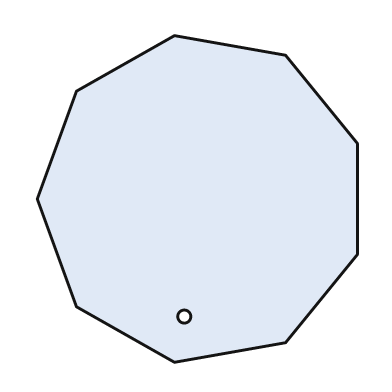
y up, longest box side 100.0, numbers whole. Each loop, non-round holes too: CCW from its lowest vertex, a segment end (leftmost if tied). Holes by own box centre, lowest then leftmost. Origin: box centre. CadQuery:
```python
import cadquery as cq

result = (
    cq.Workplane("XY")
    .moveTo(-7.0, -50.0)
    .lineTo(27.0, -44.0)
    .lineTo(49.0, -17.0)
    .lineTo(49.0, 17.0)
    .lineTo(27.0, 44.0)
    .lineTo(-7.0, 50.0)
    .lineTo(-37.0, 33.0)
    .lineTo(-49.0, 0.0)
    .lineTo(-37.0, -33.0)
    .close()
    .moveTo(-4.0, -36.0)
    .circle(2.0)
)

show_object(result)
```